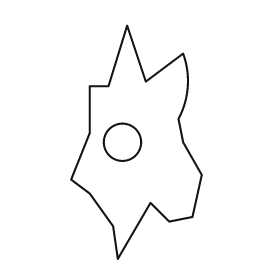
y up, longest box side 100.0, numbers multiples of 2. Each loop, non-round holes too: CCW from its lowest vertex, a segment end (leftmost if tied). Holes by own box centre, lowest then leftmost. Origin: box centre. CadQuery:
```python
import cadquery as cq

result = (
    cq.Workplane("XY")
    .moveTo(-8.0, -50.0)
    .lineTo(6.0, -26.0)
    .lineTo(14.0, -34.0)
    .lineTo(24.0, -32.0)
    .lineTo(28.0, -14.0)
    .lineTo(20.0, 0.0)
    .lineTo(18.0, 10.0)
    .threePointArc((22.0, 24.0), (20.0, 38.0))
    .lineTo(4.0, 26.0)
    .lineTo(-4.0, 50.0)
    .lineTo(-12.0, 24.0)
    .lineTo(-20.0, 24.0)
    .lineTo(-20.0, 4.0)
    .lineTo(-28.0, -16.0)
    .lineTo(-20.0, -22.0)
    .lineTo(-10.0, -36.0)
    .close()
    .moveTo(-6.0, 0.0)
    .circle(8.0)
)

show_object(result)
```